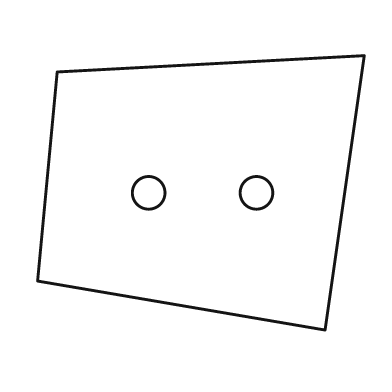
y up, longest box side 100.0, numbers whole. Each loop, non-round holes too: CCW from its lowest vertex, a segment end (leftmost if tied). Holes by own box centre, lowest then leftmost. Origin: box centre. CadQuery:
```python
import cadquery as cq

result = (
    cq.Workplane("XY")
    .moveTo(38.0, -42.0)
    .lineTo(50.0, 42.0)
    .lineTo(-44.0, 37.0)
    .lineTo(-50.0, -27.0)
    .close()
    .moveTo(-16.0, 0.0)
    .circle(5.0)
    .moveTo(17.0, 0.0)
    .circle(5.0)
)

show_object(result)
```